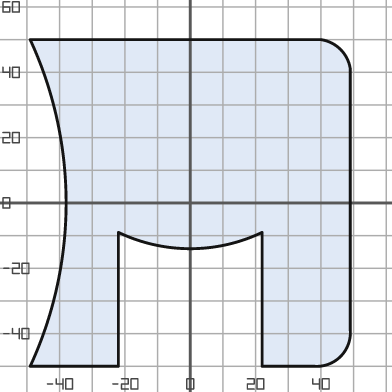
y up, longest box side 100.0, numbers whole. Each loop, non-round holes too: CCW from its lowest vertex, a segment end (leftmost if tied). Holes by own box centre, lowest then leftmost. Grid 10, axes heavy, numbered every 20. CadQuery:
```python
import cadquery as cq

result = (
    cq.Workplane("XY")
    .moveTo(-49.0, -50.0)
    .lineTo(-22.0, -50.0)
    .lineTo(-22.0, -9.0)
    .threePointArc((0.0, -14.0), (22.0, -9.0))
    .lineTo(22.0, -50.0)
    .lineTo(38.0, -50.0)
    .threePointArc((46.0, -47.0), (49.0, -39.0))
    .lineTo(49.0, 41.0)
    .threePointArc((46.0, 47.0), (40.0, 50.0))
    .lineTo(-49.0, 50.0)
    .threePointArc((-38.0, 0.0), (-49.0, -50.0))
    .close()
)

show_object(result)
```